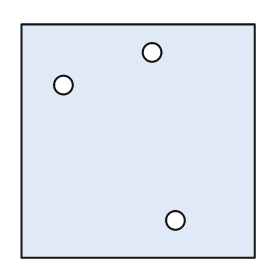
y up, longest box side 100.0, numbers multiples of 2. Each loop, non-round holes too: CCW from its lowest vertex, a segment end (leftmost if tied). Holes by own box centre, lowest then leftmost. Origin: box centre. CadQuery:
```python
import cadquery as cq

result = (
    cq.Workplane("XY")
    .moveTo(-50.0, -50.0)
    .lineTo(50.0, -50.0)
    .lineTo(50.0, 50.0)
    .lineTo(-50.0, 50.0)
    .close()
    .moveTo(16.0, -34.0)
    .circle(4.0)
    .moveTo(-32.0, 24.0)
    .circle(4.0)
    .moveTo(6.0, 38.0)
    .circle(4.0)
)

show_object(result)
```